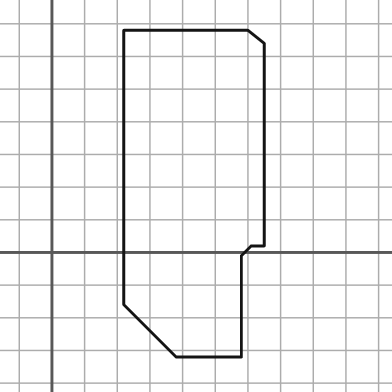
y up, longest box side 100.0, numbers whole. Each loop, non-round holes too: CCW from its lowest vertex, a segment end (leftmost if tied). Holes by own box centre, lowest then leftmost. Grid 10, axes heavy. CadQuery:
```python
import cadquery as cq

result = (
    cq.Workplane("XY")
    .moveTo(38.0, -32.0)
    .lineTo(58.0, -32.0)
    .lineTo(58.0, -1.0)
    .lineTo(61.0, 2.0)
    .lineTo(65.0, 2.0)
    .lineTo(65.0, 64.0)
    .lineTo(60.0, 68.0)
    .lineTo(22.0, 68.0)
    .lineTo(22.0, -16.0)
    .close()
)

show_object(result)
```